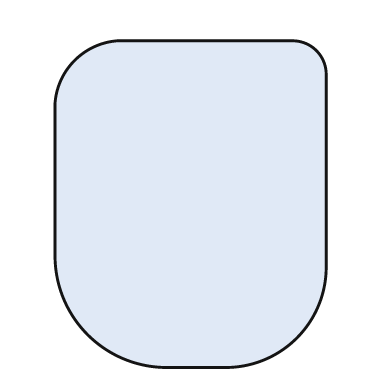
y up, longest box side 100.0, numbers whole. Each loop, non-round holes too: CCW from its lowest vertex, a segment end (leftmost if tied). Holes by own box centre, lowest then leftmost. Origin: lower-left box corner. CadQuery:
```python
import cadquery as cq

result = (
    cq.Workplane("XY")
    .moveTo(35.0, 0.0)
    .lineTo(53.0, 0.0)
    .threePointArc((74.0, 9.0), (83.0, 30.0))
    .lineTo(83.0, 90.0)
    .threePointArc((80.0, 97.0), (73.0, 100.0))
    .lineTo(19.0, 100.0)
    .threePointArc((6.0, 94.0), (0.0, 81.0))
    .lineTo(0.0, 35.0)
    .threePointArc((10.0, 10.0), (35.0, 0.0))
    .close()
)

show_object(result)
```